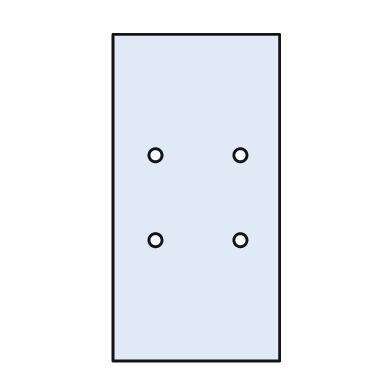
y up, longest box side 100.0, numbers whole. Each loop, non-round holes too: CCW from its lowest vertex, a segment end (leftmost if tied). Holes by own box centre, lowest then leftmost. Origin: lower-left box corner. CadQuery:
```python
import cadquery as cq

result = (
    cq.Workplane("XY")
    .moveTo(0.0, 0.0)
    .lineTo(51.0, 0.0)
    .lineTo(51.0, 100.0)
    .lineTo(0.0, 100.0)
    .close()
    .moveTo(13.0, 37.0)
    .circle(2.0)
    .moveTo(39.0, 37.0)
    .circle(2.0)
    .moveTo(13.0, 63.0)
    .circle(2.0)
    .moveTo(39.0, 63.0)
    .circle(2.0)
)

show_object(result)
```